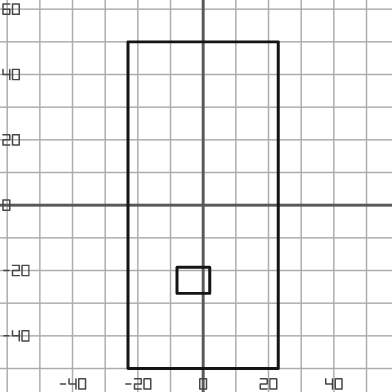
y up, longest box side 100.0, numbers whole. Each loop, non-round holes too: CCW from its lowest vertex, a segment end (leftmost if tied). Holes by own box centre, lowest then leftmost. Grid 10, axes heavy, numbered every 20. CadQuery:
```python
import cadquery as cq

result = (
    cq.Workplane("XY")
    .moveTo(-23.0, -50.0)
    .lineTo(23.0, -50.0)
    .lineTo(23.0, 50.0)
    .lineTo(-23.0, 50.0)
    .close()
    .moveTo(-8.0, -27.0)
    .lineTo(2.0, -27.0)
    .lineTo(2.0, -19.0)
    .lineTo(-8.0, -19.0)
    .close()
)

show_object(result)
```